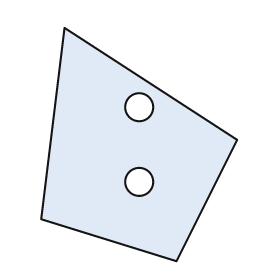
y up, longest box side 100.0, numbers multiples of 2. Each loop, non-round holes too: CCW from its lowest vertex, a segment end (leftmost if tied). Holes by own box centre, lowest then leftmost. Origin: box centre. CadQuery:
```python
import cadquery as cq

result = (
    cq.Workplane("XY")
    .moveTo(16.0, -50.0)
    .lineTo(42.0, 2.0)
    .lineTo(-32.0, 50.0)
    .lineTo(-42.0, -32.0)
    .close()
    .moveTo(0.0, -16.0)
    .circle(6.0)
    .moveTo(0.0, 16.0)
    .circle(6.0)
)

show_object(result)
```